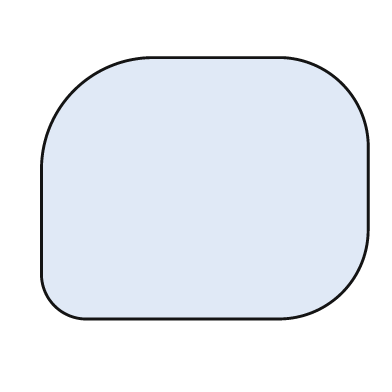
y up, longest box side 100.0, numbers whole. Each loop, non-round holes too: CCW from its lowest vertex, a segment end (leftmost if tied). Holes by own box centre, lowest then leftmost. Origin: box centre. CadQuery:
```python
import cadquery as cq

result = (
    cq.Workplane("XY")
    .moveTo(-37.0, -40.0)
    .lineTo(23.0, -40.0)
    .threePointArc((42.0, -32.0), (50.0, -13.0))
    .lineTo(50.0, 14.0)
    .threePointArc((42.0, 32.0), (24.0, 40.0))
    .lineTo(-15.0, 40.0)
    .threePointArc((-40.0, 30.0), (-50.0, 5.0))
    .lineTo(-50.0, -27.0)
    .threePointArc((-46.0, -36.0), (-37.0, -40.0))
    .close()
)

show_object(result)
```